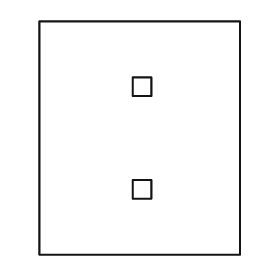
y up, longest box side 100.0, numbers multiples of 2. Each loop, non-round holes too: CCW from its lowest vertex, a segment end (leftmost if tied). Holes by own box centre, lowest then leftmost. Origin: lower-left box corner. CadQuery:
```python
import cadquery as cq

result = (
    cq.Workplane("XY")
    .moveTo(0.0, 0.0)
    .lineTo(86.0, 0.0)
    .lineTo(86.0, 100.0)
    .lineTo(0.0, 100.0)
    .close()
    .moveTo(40.0, 24.0)
    .lineTo(48.0, 24.0)
    .lineTo(48.0, 32.0)
    .lineTo(40.0, 32.0)
    .close()
    .moveTo(40.0, 68.0)
    .lineTo(48.0, 68.0)
    .lineTo(48.0, 76.0)
    .lineTo(40.0, 76.0)
    .close()
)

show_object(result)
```